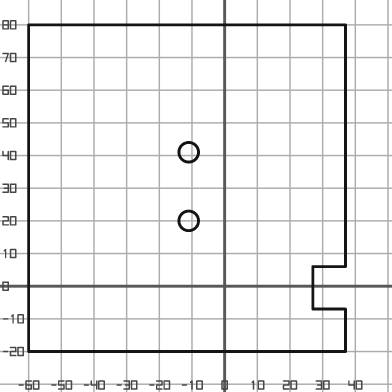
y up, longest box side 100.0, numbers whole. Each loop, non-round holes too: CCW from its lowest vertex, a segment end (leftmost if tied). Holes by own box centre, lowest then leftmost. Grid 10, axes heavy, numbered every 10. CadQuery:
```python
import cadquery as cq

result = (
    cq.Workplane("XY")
    .moveTo(-60.0, -20.0)
    .lineTo(37.0, -20.0)
    .lineTo(37.0, -7.0)
    .lineTo(27.0, -7.0)
    .lineTo(27.0, 6.0)
    .lineTo(37.0, 6.0)
    .lineTo(37.0, 80.0)
    .lineTo(-60.0, 80.0)
    .close()
    .moveTo(-11.0, 20.0)
    .circle(3.0)
    .moveTo(-11.0, 41.0)
    .circle(3.0)
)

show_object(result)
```